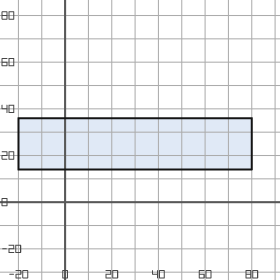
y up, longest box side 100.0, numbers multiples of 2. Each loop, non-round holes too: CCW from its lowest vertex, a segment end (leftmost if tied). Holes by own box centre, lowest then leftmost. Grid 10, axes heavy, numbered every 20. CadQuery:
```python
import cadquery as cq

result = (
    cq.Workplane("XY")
    .moveTo(-20.0, 14.0)
    .lineTo(80.0, 14.0)
    .lineTo(80.0, 36.0)
    .lineTo(-20.0, 36.0)
    .close()
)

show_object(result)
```